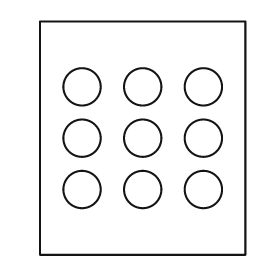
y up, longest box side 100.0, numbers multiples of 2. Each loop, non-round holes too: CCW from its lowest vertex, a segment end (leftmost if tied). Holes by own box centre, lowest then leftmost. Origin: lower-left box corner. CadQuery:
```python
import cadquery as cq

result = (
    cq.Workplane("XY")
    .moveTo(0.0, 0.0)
    .lineTo(88.0, 0.0)
    .lineTo(88.0, 100.0)
    .lineTo(0.0, 100.0)
    .close()
    .moveTo(18.0, 28.0)
    .circle(8.0)
    .moveTo(44.0, 28.0)
    .circle(8.0)
    .moveTo(70.0, 28.0)
    .circle(8.0)
    .moveTo(18.0, 50.0)
    .circle(8.0)
    .moveTo(44.0, 50.0)
    .circle(8.0)
    .moveTo(70.0, 50.0)
    .circle(8.0)
    .moveTo(18.0, 72.0)
    .circle(8.0)
    .moveTo(44.0, 72.0)
    .circle(8.0)
    .moveTo(70.0, 72.0)
    .circle(8.0)
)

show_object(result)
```